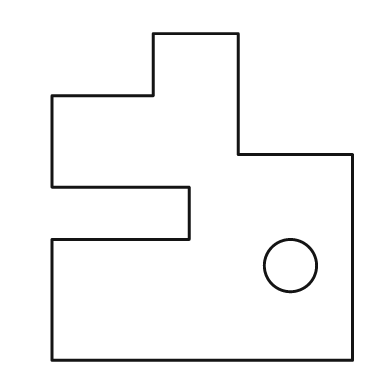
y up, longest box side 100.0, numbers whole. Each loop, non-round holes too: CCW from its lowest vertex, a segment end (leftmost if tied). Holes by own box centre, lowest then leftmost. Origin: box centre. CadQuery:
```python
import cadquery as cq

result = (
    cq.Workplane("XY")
    .moveTo(-46.0, -50.0)
    .lineTo(46.0, -50.0)
    .lineTo(46.0, 13.0)
    .lineTo(11.0, 13.0)
    .lineTo(11.0, 50.0)
    .lineTo(-15.0, 50.0)
    .lineTo(-15.0, 31.0)
    .lineTo(-46.0, 31.0)
    .lineTo(-46.0, 3.0)
    .lineTo(-4.0, 3.0)
    .lineTo(-4.0, -13.0)
    .lineTo(-46.0, -13.0)
    .close()
    .moveTo(27.0, -21.0)
    .circle(8.0)
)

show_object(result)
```